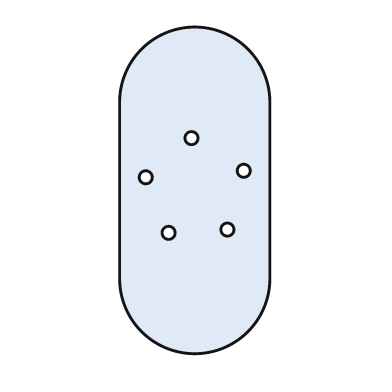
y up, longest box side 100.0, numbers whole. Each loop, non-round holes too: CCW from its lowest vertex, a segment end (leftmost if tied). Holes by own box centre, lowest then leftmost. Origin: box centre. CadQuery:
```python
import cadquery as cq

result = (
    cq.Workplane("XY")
    .moveTo(-23.0, -27.0)
    .threePointArc((0.0, -50.0), (23.0, -27.0))
    .lineTo(23.0, 27.0)
    .threePointArc((0.0, 50.0), (-23.0, 27.0))
    .close()
    .moveTo(-8.0, -13.0)
    .circle(2.0)
    .moveTo(10.0, -12.0)
    .circle(2.0)
    .moveTo(-15.0, 4.0)
    .circle(2.0)
    .moveTo(15.0, 6.0)
    .circle(2.0)
    .moveTo(-1.0, 16.0)
    .circle(2.0)
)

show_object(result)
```